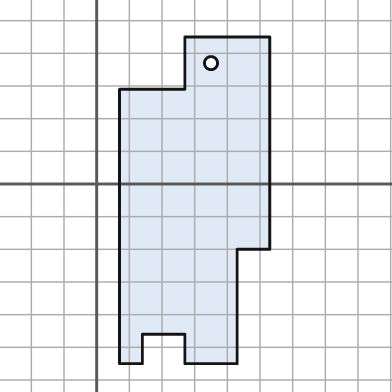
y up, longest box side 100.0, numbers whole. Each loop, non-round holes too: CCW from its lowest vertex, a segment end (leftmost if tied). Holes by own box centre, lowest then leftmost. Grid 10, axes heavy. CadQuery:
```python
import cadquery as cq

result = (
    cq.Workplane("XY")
    .moveTo(7.0, -55.0)
    .lineTo(14.0, -55.0)
    .lineTo(14.0, -46.0)
    .lineTo(27.0, -46.0)
    .lineTo(27.0, -55.0)
    .lineTo(43.0, -55.0)
    .lineTo(43.0, -20.0)
    .lineTo(53.0, -20.0)
    .lineTo(53.0, 45.0)
    .lineTo(27.0, 45.0)
    .lineTo(27.0, 29.0)
    .lineTo(7.0, 29.0)
    .close()
    .moveTo(35.0, 37.0)
    .circle(2.0)
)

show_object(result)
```